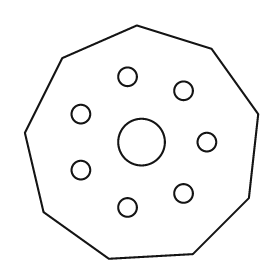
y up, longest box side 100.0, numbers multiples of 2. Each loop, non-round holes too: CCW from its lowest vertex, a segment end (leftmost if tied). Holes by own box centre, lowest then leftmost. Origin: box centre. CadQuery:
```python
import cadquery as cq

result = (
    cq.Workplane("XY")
    .moveTo(-14.0, -50.0)
    .lineTo(22.0, -48.0)
    .lineTo(46.0, -24.0)
    .lineTo(50.0, 12.0)
    .lineTo(30.0, 40.0)
    .lineTo(-2.0, 50.0)
    .lineTo(-34.0, 36.0)
    .lineTo(-50.0, 4.0)
    .lineTo(-42.0, -30.0)
    .close()
    .moveTo(-6.0, -28.0)
    .circle(4.0)
    .moveTo(18.0, -22.0)
    .circle(4.0)
    .moveTo(-26.0, -12.0)
    .circle(4.0)
    .moveTo(0.0, 0.0)
    .circle(10.0)
    .moveTo(28.0, 0.0)
    .circle(4.0)
    .moveTo(-26.0, 12.0)
    .circle(4.0)
    .moveTo(18.0, 22.0)
    .circle(4.0)
    .moveTo(-6.0, 28.0)
    .circle(4.0)
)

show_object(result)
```